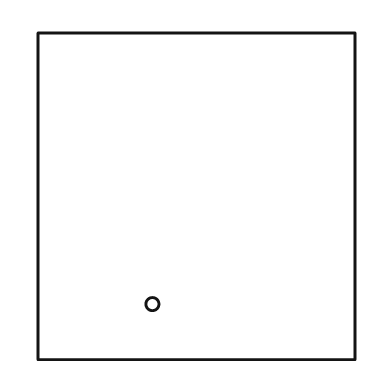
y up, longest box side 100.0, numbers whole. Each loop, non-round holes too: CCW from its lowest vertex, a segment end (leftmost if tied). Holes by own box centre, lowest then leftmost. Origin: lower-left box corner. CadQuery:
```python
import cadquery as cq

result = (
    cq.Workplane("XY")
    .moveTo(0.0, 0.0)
    .lineTo(97.0, 0.0)
    .lineTo(97.0, 100.0)
    .lineTo(0.0, 100.0)
    .close()
    .moveTo(35.0, 17.0)
    .circle(2.0)
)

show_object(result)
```